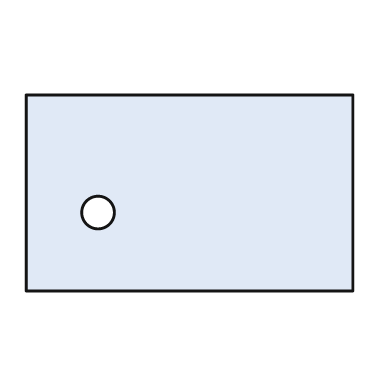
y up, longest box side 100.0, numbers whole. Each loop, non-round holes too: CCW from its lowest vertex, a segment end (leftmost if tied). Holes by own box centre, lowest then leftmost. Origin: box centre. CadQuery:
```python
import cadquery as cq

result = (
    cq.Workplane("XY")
    .moveTo(-50.0, -30.0)
    .lineTo(50.0, -30.0)
    .lineTo(50.0, 30.0)
    .lineTo(-50.0, 30.0)
    .close()
    .moveTo(-28.0, -6.0)
    .circle(5.0)
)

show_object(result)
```